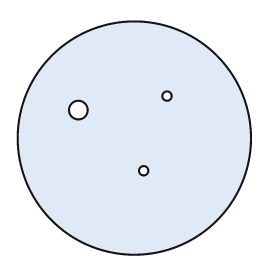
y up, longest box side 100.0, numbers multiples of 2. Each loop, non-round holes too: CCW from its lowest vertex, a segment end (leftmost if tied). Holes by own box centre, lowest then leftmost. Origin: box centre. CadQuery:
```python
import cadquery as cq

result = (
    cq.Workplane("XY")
    .moveTo(0.0, 0.0)
    .circle(50.0)
    .moveTo(4.0, -14.0)
    .circle(2.0)
    .moveTo(-24.0, 12.0)
    .circle(4.0)
    .moveTo(14.0, 18.0)
    .circle(2.0)
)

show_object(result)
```